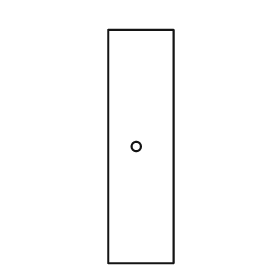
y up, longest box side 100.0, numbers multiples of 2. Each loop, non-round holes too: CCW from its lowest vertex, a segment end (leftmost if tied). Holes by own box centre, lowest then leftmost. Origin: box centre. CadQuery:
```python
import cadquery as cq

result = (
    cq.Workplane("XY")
    .moveTo(-14.0, -50.0)
    .lineTo(14.0, -50.0)
    .lineTo(14.0, 50.0)
    .lineTo(-14.0, 50.0)
    .close()
    .moveTo(-2.0, 0.0)
    .circle(2.0)
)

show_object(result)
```